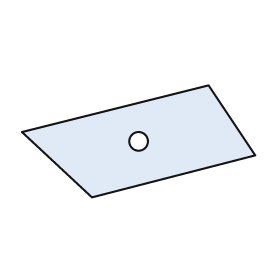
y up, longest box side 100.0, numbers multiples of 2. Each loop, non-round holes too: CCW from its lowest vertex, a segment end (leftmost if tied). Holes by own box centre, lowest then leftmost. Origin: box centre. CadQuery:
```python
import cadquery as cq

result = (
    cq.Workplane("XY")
    .moveTo(-20.0, -24.0)
    .lineTo(50.0, -6.0)
    .lineTo(30.0, 24.0)
    .lineTo(-50.0, 4.0)
    .close()
    .moveTo(0.0, 0.0)
    .circle(4.0)
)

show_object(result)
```